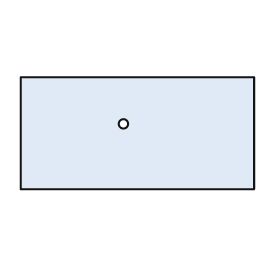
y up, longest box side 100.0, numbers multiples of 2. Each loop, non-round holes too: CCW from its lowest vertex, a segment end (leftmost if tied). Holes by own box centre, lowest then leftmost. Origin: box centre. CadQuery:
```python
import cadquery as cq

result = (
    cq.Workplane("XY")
    .moveTo(-50.0, -24.0)
    .lineTo(50.0, -24.0)
    .lineTo(50.0, 24.0)
    .lineTo(-50.0, 24.0)
    .close()
    .moveTo(-6.0, 4.0)
    .circle(2.0)
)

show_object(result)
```